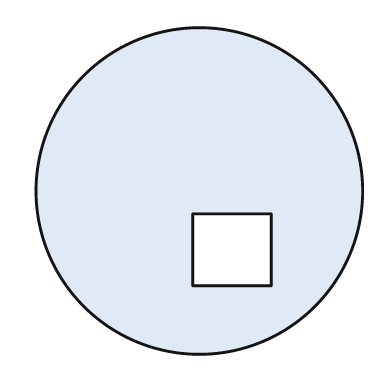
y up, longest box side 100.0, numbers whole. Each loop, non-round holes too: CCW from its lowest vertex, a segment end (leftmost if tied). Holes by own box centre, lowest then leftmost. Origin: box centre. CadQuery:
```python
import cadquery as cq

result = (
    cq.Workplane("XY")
    .moveTo(0.0, 0.0)
    .circle(50.0)
    .moveTo(-2.0, -29.0)
    .lineTo(22.0, -29.0)
    .lineTo(22.0, -7.0)
    .lineTo(-2.0, -7.0)
    .close()
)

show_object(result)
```